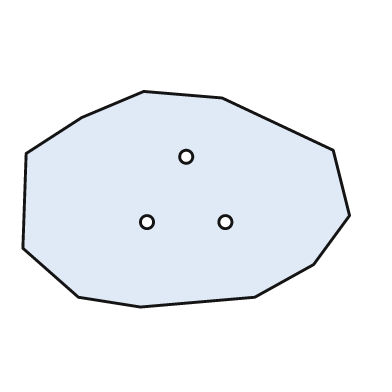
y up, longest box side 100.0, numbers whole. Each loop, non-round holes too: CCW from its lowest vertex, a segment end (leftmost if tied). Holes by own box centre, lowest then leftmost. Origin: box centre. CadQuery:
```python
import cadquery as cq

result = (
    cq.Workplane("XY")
    .moveTo(-14.0, -33.0)
    .lineTo(21.0, -30.0)
    .lineTo(39.0, -20.0)
    .lineTo(50.0, -5.0)
    .lineTo(45.0, 15.0)
    .lineTo(11.0, 31.0)
    .lineTo(-13.0, 33.0)
    .lineTo(-32.0, 25.0)
    .lineTo(-49.0, 14.0)
    .lineTo(-50.0, -15.0)
    .lineTo(-33.0, -30.0)
    .close()
    .moveTo(-12.0, -7.0)
    .circle(2.0)
    .moveTo(12.0, -7.0)
    .circle(2.0)
    .moveTo(0.0, 13.0)
    .circle(2.0)
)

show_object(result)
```